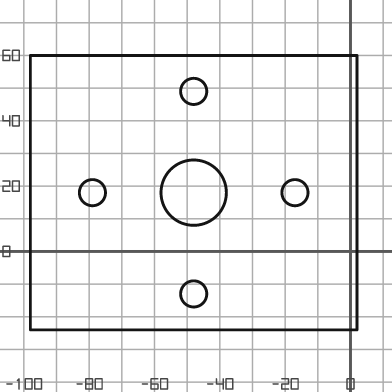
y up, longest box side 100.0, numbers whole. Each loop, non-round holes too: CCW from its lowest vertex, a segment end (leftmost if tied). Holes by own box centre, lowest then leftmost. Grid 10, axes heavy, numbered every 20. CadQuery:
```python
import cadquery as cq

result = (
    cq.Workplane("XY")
    .moveTo(-98.0, -24.0)
    .lineTo(2.0, -24.0)
    .lineTo(2.0, 60.0)
    .lineTo(-98.0, 60.0)
    .close()
    .moveTo(-48.0, -13.0)
    .circle(4.0)
    .moveTo(-79.0, 18.0)
    .circle(4.0)
    .moveTo(-48.0, 18.0)
    .circle(10.0)
    .moveTo(-17.0, 18.0)
    .circle(4.0)
    .moveTo(-48.0, 49.0)
    .circle(4.0)
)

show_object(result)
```